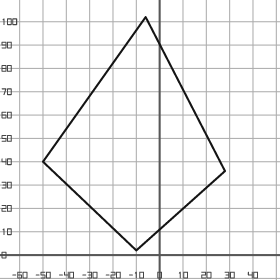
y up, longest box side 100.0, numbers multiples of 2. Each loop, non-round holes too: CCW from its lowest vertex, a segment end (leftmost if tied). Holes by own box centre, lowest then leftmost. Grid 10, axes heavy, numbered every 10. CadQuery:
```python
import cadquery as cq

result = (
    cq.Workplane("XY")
    .moveTo(-10.0, 2.0)
    .lineTo(28.0, 36.0)
    .lineTo(-6.0, 102.0)
    .lineTo(-50.0, 40.0)
    .close()
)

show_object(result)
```